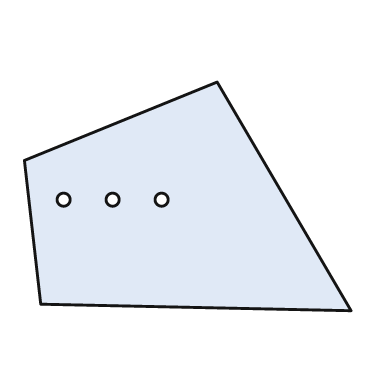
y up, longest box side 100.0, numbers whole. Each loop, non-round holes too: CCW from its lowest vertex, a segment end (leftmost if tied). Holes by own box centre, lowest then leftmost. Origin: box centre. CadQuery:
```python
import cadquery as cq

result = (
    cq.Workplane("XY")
    .moveTo(50.0, -35.0)
    .lineTo(9.0, 35.0)
    .lineTo(-50.0, 11.0)
    .lineTo(-45.0, -33.0)
    .close()
    .moveTo(-38.0, -1.0)
    .circle(2.0)
    .moveTo(-23.0, -1.0)
    .circle(2.0)
    .moveTo(-8.0, -1.0)
    .circle(2.0)
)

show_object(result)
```